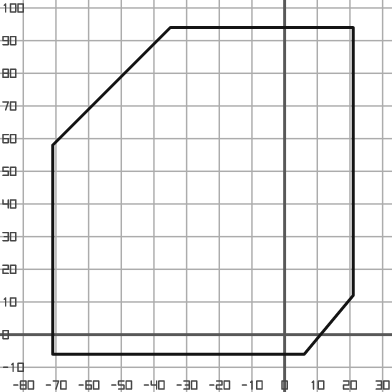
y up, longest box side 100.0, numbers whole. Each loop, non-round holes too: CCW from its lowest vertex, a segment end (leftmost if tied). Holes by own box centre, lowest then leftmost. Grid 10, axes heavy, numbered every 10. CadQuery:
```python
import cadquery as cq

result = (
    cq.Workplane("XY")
    .moveTo(-71.0, -6.0)
    .lineTo(6.0, -6.0)
    .lineTo(21.0, 12.0)
    .lineTo(21.0, 94.0)
    .lineTo(-35.0, 94.0)
    .lineTo(-71.0, 58.0)
    .close()
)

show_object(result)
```